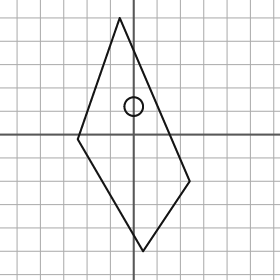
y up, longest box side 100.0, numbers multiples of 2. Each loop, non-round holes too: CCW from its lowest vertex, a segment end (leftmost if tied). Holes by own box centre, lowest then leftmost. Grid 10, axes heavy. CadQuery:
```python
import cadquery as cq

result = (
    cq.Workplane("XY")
    .moveTo(4.0, -50.0)
    .lineTo(24.0, -20.0)
    .lineTo(-6.0, 50.0)
    .lineTo(-24.0, -2.0)
    .close()
    .moveTo(0.0, 12.0)
    .circle(4.0)
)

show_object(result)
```